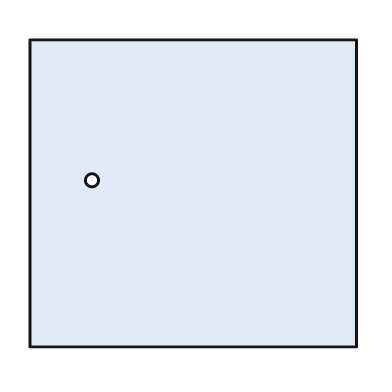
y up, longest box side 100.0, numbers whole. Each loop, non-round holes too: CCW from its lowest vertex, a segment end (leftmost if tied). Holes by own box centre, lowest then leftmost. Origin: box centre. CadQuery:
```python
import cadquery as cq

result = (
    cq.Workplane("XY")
    .moveTo(-50.0, -47.0)
    .lineTo(50.0, -47.0)
    .lineTo(50.0, 47.0)
    .lineTo(-50.0, 47.0)
    .close()
    .moveTo(-31.0, 4.0)
    .circle(2.0)
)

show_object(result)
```